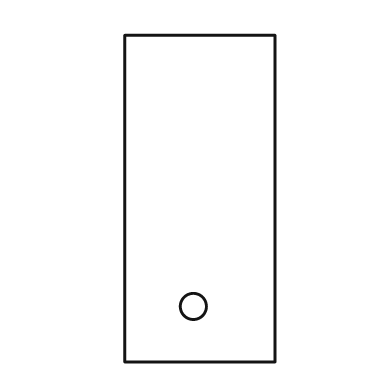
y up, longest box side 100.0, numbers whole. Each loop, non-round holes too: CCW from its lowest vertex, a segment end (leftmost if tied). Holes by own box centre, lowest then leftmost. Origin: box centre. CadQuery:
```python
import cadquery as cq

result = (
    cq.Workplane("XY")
    .moveTo(-23.0, -50.0)
    .lineTo(23.0, -50.0)
    .lineTo(23.0, 50.0)
    .lineTo(-23.0, 50.0)
    .close()
    .moveTo(-2.0, -33.0)
    .circle(4.0)
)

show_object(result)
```